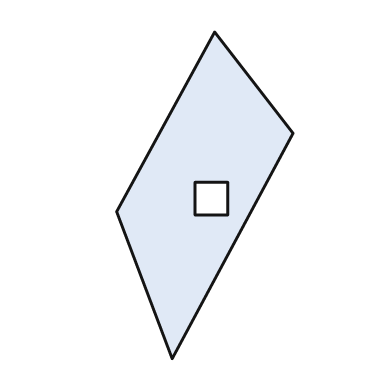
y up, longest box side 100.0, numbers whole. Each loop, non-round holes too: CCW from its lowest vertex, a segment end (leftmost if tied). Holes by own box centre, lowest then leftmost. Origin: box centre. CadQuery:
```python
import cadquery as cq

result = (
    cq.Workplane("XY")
    .moveTo(-10.0, -50.0)
    .lineTo(27.0, 19.0)
    .lineTo(3.0, 50.0)
    .lineTo(-27.0, -5.0)
    .close()
    .moveTo(-3.0, -6.0)
    .lineTo(7.0, -6.0)
    .lineTo(7.0, 4.0)
    .lineTo(-3.0, 4.0)
    .close()
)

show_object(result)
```